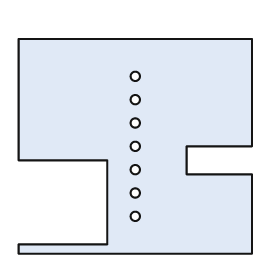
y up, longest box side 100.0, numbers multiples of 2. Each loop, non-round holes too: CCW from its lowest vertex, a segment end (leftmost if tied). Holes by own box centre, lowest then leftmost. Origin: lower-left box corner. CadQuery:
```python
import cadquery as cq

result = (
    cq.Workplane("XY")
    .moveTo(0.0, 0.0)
    .lineTo(100.0, 0.0)
    .lineTo(100.0, 34.0)
    .lineTo(72.0, 34.0)
    .lineTo(72.0, 46.0)
    .lineTo(100.0, 46.0)
    .lineTo(100.0, 92.0)
    .lineTo(0.0, 92.0)
    .lineTo(0.0, 40.0)
    .lineTo(38.0, 40.0)
    .lineTo(38.0, 4.0)
    .lineTo(0.0, 4.0)
    .close()
    .moveTo(50.0, 16.0)
    .circle(2.0)
    .moveTo(50.0, 26.0)
    .circle(2.0)
    .moveTo(50.0, 36.0)
    .circle(2.0)
    .moveTo(50.0, 46.0)
    .circle(2.0)
    .moveTo(50.0, 56.0)
    .circle(2.0)
    .moveTo(50.0, 66.0)
    .circle(2.0)
    .moveTo(50.0, 76.0)
    .circle(2.0)
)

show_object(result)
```